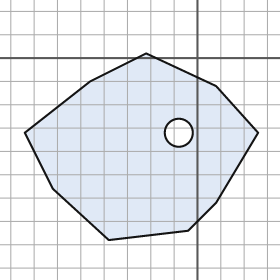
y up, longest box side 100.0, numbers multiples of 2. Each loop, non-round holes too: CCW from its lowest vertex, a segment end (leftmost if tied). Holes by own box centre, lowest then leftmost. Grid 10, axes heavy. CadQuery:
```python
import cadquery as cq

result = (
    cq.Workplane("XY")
    .moveTo(-38.0, -78.0)
    .lineTo(-4.0, -74.0)
    .lineTo(8.0, -62.0)
    .lineTo(26.0, -32.0)
    .lineTo(8.0, -12.0)
    .lineTo(-22.0, 2.0)
    .lineTo(-46.0, -10.0)
    .lineTo(-74.0, -32.0)
    .lineTo(-62.0, -56.0)
    .close()
    .moveTo(-8.0, -32.0)
    .circle(6.0)
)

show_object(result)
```